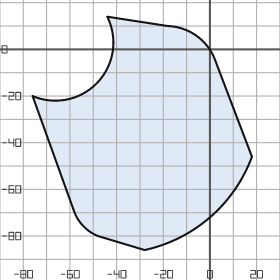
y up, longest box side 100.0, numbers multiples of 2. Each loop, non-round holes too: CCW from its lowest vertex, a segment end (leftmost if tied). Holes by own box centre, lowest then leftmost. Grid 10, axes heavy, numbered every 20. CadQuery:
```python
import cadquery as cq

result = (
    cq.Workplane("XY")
    .moveTo(-28.0, -86.0)
    .threePointArc((0.0, -72.0), (18.0, -46.0))
    .lineTo(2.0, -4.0)
    .threePointArc((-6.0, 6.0), (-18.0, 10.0))
    .lineTo(-44.0, 14.0)
    .threePointArc((-48.0, -14.0), (-76.0, -20.0))
    .lineTo(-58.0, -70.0)
    .threePointArc((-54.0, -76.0), (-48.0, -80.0))
    .close()
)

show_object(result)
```